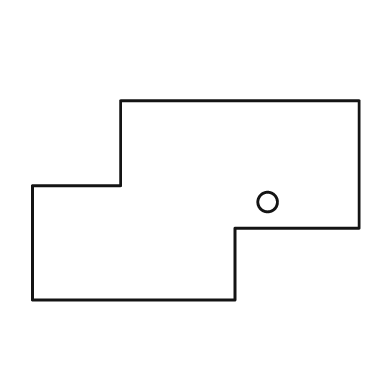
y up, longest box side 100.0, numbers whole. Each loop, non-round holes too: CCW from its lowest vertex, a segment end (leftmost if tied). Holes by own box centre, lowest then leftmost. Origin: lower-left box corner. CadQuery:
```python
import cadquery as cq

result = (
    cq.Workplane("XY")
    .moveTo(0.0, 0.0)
    .lineTo(62.0, 0.0)
    .lineTo(62.0, 22.0)
    .lineTo(100.0, 22.0)
    .lineTo(100.0, 61.0)
    .lineTo(27.0, 61.0)
    .lineTo(27.0, 35.0)
    .lineTo(0.0, 35.0)
    .close()
    .moveTo(72.0, 30.0)
    .circle(3.0)
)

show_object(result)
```